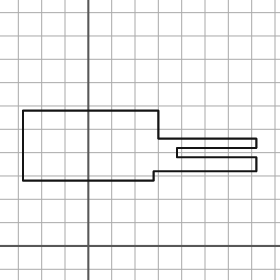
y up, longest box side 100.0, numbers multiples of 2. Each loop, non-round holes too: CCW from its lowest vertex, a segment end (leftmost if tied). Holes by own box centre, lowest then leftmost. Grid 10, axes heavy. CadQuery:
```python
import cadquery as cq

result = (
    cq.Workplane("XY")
    .moveTo(-28.0, 28.0)
    .lineTo(28.0, 28.0)
    .lineTo(28.0, 32.0)
    .lineTo(72.0, 32.0)
    .lineTo(72.0, 38.0)
    .lineTo(38.0, 38.0)
    .lineTo(38.0, 42.0)
    .lineTo(72.0, 42.0)
    .lineTo(72.0, 46.0)
    .lineTo(30.0, 46.0)
    .lineTo(30.0, 58.0)
    .lineTo(-28.0, 58.0)
    .close()
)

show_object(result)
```